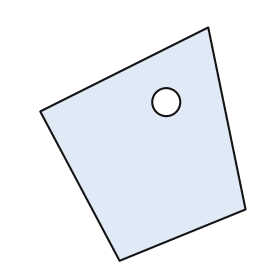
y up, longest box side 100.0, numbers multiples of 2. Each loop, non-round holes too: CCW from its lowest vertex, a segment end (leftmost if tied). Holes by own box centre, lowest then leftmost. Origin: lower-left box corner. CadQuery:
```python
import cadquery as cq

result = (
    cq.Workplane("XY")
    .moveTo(34.0, 0.0)
    .lineTo(88.0, 22.0)
    .lineTo(72.0, 100.0)
    .lineTo(0.0, 64.0)
    .close()
    .moveTo(54.0, 68.0)
    .circle(6.0)
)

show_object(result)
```